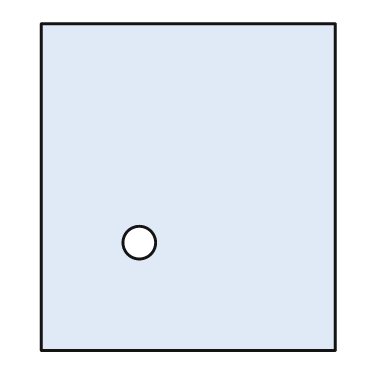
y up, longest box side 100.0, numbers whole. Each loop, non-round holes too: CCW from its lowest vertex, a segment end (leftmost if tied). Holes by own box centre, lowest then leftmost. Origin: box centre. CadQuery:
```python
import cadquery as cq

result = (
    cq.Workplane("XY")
    .moveTo(-45.0, -50.0)
    .lineTo(45.0, -50.0)
    .lineTo(45.0, 50.0)
    .lineTo(-45.0, 50.0)
    .close()
    .moveTo(-15.0, -17.0)
    .circle(5.0)
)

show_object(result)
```